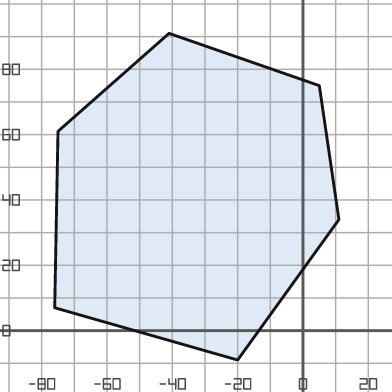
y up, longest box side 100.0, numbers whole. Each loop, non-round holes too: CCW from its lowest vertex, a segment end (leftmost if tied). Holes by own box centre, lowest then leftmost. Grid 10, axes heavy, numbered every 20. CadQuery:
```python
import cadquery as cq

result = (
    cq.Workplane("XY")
    .moveTo(-20.0, -9.0)
    .lineTo(11.0, 34.0)
    .lineTo(5.0, 75.0)
    .lineTo(-41.0, 91.0)
    .lineTo(-75.0, 61.0)
    .lineTo(-76.0, 7.0)
    .close()
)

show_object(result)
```